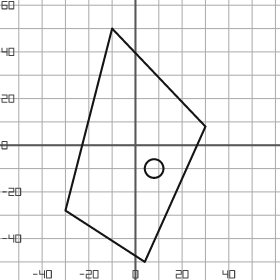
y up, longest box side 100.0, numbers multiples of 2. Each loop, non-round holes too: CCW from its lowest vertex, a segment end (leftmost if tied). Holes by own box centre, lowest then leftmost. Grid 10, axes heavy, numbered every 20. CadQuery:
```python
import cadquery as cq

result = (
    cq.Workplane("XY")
    .moveTo(4.0, -50.0)
    .lineTo(30.0, 8.0)
    .lineTo(-10.0, 50.0)
    .lineTo(-30.0, -28.0)
    .close()
    .moveTo(8.0, -10.0)
    .circle(4.0)
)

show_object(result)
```